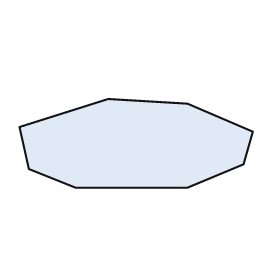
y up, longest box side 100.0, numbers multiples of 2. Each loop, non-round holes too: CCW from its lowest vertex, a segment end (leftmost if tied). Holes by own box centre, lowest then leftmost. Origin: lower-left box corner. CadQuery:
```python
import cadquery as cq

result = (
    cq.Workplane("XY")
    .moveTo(24.0, 0.0)
    .lineTo(72.0, 0.0)
    .lineTo(96.0, 10.0)
    .lineTo(100.0, 24.0)
    .lineTo(72.0, 36.0)
    .lineTo(38.0, 38.0)
    .lineTo(0.0, 26.0)
    .lineTo(4.0, 8.0)
    .close()
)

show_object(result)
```